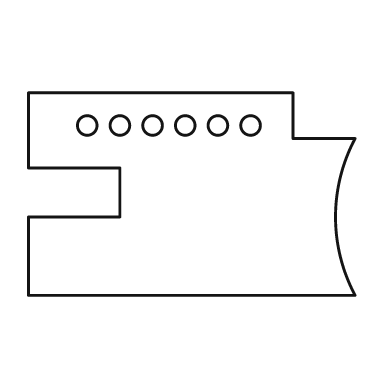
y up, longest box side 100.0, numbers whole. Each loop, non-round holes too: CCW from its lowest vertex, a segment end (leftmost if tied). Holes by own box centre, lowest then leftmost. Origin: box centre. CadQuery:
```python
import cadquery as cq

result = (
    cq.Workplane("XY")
    .moveTo(-50.0, -31.0)
    .lineTo(50.0, -31.0)
    .threePointArc((44.0, -7.0), (50.0, 17.0))
    .lineTo(31.0, 17.0)
    .lineTo(31.0, 31.0)
    .lineTo(-50.0, 31.0)
    .lineTo(-50.0, 8.0)
    .lineTo(-22.0, 8.0)
    .lineTo(-22.0, -7.0)
    .lineTo(-50.0, -7.0)
    .close()
    .moveTo(-32.0, 21.0)
    .circle(3.0)
    .moveTo(-22.0, 21.0)
    .circle(3.0)
    .moveTo(-12.0, 21.0)
    .circle(3.0)
    .moveTo(-2.0, 21.0)
    .circle(3.0)
    .moveTo(8.0, 21.0)
    .circle(3.0)
    .moveTo(18.0, 21.0)
    .circle(3.0)
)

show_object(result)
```